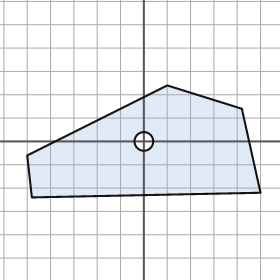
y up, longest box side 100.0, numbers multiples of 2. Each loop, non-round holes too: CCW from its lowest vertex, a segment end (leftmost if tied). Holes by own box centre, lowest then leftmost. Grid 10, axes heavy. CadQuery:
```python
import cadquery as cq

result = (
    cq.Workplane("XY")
    .moveTo(-48.0, -24.0)
    .lineTo(50.0, -22.0)
    .lineTo(42.0, 14.0)
    .lineTo(10.0, 24.0)
    .lineTo(-50.0, -6.0)
    .close()
    .moveTo(0.0, 0.0)
    .circle(4.0)
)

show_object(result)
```